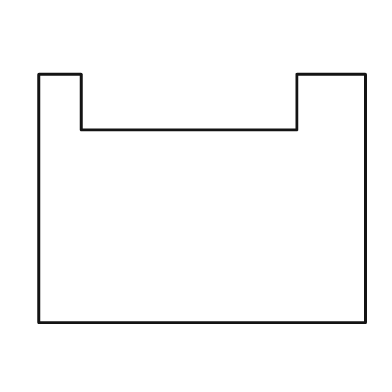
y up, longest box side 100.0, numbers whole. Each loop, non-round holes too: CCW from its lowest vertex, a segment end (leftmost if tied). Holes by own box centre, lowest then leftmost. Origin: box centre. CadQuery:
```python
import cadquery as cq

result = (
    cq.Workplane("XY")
    .moveTo(-50.0, -38.0)
    .lineTo(50.0, -38.0)
    .lineTo(50.0, 38.0)
    .lineTo(29.0, 38.0)
    .lineTo(29.0, 21.0)
    .lineTo(-37.0, 21.0)
    .lineTo(-37.0, 38.0)
    .lineTo(-50.0, 38.0)
    .close()
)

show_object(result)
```